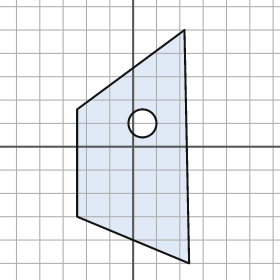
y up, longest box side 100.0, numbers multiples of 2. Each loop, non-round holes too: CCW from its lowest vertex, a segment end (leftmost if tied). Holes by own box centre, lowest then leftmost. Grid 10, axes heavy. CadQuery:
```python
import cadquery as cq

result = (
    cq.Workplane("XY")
    .moveTo(24.0, -50.0)
    .lineTo(22.0, 50.0)
    .lineTo(-24.0, 16.0)
    .lineTo(-24.0, -30.0)
    .close()
    .moveTo(4.0, 10.0)
    .circle(6.0)
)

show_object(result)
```